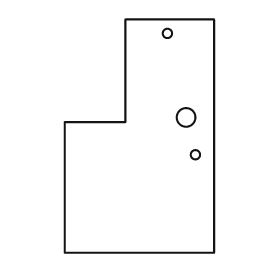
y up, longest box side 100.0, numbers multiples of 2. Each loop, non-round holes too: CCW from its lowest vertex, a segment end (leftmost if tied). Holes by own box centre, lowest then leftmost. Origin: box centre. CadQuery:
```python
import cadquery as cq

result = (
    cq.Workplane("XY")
    .moveTo(-32.0, -50.0)
    .lineTo(32.0, -50.0)
    .lineTo(32.0, 50.0)
    .lineTo(-6.0, 50.0)
    .lineTo(-6.0, 6.0)
    .lineTo(-32.0, 6.0)
    .close()
    .moveTo(24.0, -8.0)
    .circle(2.0)
    .moveTo(20.0, 8.0)
    .circle(4.0)
    .moveTo(12.0, 44.0)
    .circle(2.0)
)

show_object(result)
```